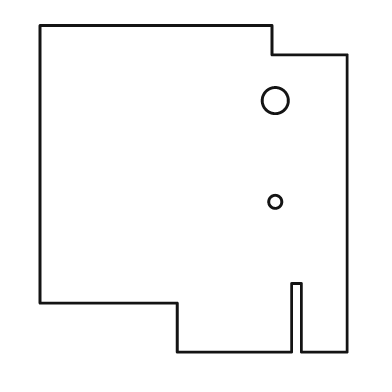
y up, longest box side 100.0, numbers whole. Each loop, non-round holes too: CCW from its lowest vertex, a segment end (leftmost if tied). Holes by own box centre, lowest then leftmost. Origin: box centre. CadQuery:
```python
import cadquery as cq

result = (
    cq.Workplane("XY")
    .moveTo(-5.0, -50.0)
    .lineTo(30.0, -50.0)
    .lineTo(30.0, -29.0)
    .lineTo(33.0, -29.0)
    .lineTo(33.0, -50.0)
    .lineTo(47.0, -50.0)
    .lineTo(47.0, 41.0)
    .lineTo(24.0, 41.0)
    .lineTo(24.0, 50.0)
    .lineTo(-47.0, 50.0)
    .lineTo(-47.0, -35.0)
    .lineTo(-5.0, -35.0)
    .close()
    .moveTo(25.0, -4.0)
    .circle(2.0)
    .moveTo(25.0, 27.0)
    .circle(4.0)
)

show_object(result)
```